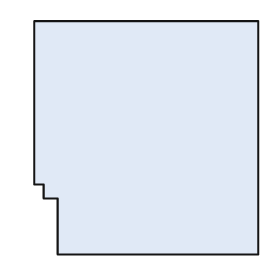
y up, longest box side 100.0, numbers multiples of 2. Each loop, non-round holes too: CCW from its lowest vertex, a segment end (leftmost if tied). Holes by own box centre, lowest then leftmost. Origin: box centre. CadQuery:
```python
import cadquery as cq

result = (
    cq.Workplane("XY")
    .moveTo(-38.0, -50.0)
    .lineTo(48.0, -50.0)
    .lineTo(48.0, 50.0)
    .lineTo(-48.0, 50.0)
    .lineTo(-48.0, -20.0)
    .lineTo(-44.0, -20.0)
    .lineTo(-44.0, -26.0)
    .lineTo(-38.0, -26.0)
    .close()
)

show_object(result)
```